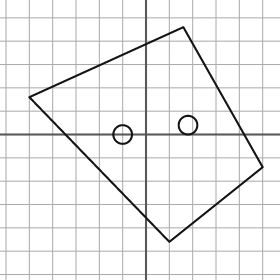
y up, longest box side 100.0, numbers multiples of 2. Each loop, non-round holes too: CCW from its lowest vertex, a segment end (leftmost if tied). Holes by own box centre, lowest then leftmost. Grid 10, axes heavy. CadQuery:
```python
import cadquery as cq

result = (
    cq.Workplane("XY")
    .moveTo(10.0, -46.0)
    .lineTo(50.0, -14.0)
    .lineTo(16.0, 46.0)
    .lineTo(-50.0, 16.0)
    .close()
    .moveTo(-10.0, 0.0)
    .circle(4.0)
    .moveTo(18.0, 4.0)
    .circle(4.0)
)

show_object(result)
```